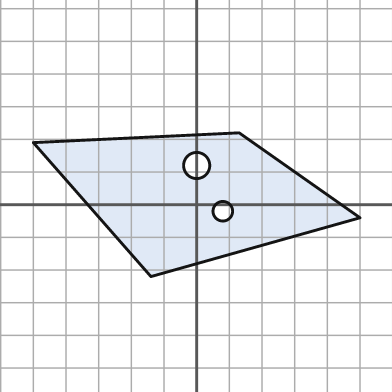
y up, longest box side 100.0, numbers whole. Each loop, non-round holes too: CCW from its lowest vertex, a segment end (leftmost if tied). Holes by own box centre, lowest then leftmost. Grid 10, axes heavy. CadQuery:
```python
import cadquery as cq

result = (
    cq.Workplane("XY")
    .moveTo(-14.0, -22.0)
    .lineTo(50.0, -4.0)
    .lineTo(13.0, 22.0)
    .lineTo(-50.0, 19.0)
    .close()
    .moveTo(8.0, -2.0)
    .circle(3.0)
    .moveTo(0.0, 12.0)
    .circle(4.0)
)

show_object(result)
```